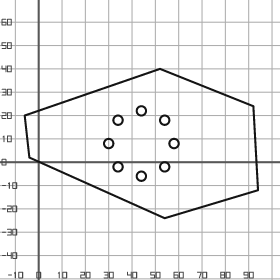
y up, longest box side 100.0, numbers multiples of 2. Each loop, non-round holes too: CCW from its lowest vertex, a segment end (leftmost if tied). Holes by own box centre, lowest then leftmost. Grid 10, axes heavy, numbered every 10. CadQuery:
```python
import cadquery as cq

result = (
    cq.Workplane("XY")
    .moveTo(54.0, -24.0)
    .lineTo(94.0, -12.0)
    .lineTo(92.0, 24.0)
    .lineTo(52.0, 40.0)
    .lineTo(-6.0, 20.0)
    .lineTo(-4.0, 2.0)
    .close()
    .moveTo(44.0, -6.0)
    .circle(2.0)
    .moveTo(34.0, -2.0)
    .circle(2.0)
    .moveTo(54.0, -2.0)
    .circle(2.0)
    .moveTo(30.0, 8.0)
    .circle(2.0)
    .moveTo(58.0, 8.0)
    .circle(2.0)
    .moveTo(34.0, 18.0)
    .circle(2.0)
    .moveTo(54.0, 18.0)
    .circle(2.0)
    .moveTo(44.0, 22.0)
    .circle(2.0)
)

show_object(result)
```